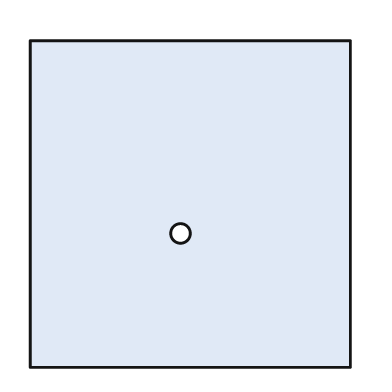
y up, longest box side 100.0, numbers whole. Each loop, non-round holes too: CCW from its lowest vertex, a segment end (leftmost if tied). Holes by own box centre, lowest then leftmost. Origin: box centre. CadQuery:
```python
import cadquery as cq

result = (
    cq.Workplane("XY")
    .moveTo(-49.0, -50.0)
    .lineTo(49.0, -50.0)
    .lineTo(49.0, 50.0)
    .lineTo(-49.0, 50.0)
    .close()
    .moveTo(-3.0, -9.0)
    .circle(3.0)
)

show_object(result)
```